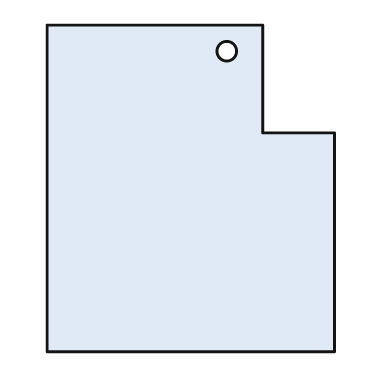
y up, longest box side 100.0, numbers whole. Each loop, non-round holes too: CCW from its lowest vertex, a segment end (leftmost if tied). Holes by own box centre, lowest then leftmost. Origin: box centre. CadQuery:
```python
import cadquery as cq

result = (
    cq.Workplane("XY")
    .moveTo(-44.0, -50.0)
    .lineTo(44.0, -50.0)
    .lineTo(44.0, 17.0)
    .lineTo(22.0, 17.0)
    .lineTo(22.0, 50.0)
    .lineTo(-44.0, 50.0)
    .close()
    .moveTo(11.0, 42.0)
    .circle(3.0)
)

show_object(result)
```